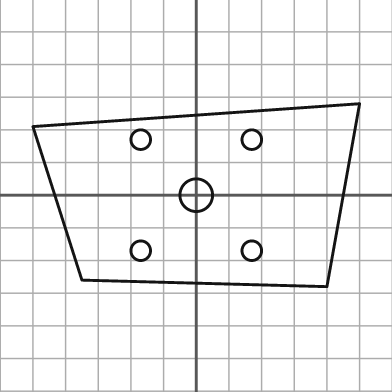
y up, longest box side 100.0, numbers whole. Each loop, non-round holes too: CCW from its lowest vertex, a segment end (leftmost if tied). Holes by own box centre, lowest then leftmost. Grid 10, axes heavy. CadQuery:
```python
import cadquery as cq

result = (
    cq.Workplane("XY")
    .moveTo(40.0, -28.0)
    .lineTo(50.0, 28.0)
    .lineTo(-50.0, 21.0)
    .lineTo(-35.0, -26.0)
    .close()
    .moveTo(-17.0, -17.0)
    .circle(3.0)
    .moveTo(17.0, -17.0)
    .circle(3.0)
    .moveTo(0.0, 0.0)
    .circle(5.0)
    .moveTo(-17.0, 17.0)
    .circle(3.0)
    .moveTo(17.0, 17.0)
    .circle(3.0)
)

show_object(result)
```